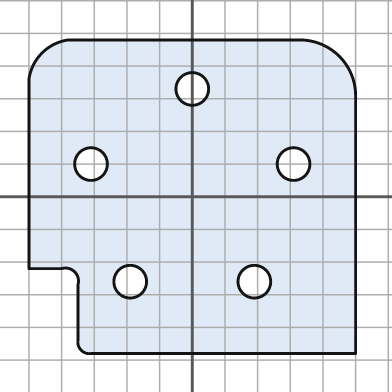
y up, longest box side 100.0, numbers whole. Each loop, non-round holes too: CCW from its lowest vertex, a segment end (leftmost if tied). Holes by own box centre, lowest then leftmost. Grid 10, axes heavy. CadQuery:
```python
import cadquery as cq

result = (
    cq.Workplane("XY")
    .moveTo(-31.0, -48.0)
    .lineTo(50.0, -48.0)
    .lineTo(50.0, 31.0)
    .threePointArc((45.0, 43.0), (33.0, 48.0))
    .lineTo(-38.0, 48.0)
    .threePointArc((-46.0, 44.0), (-50.0, 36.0))
    .lineTo(-50.0, -22.0)
    .lineTo(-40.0, -22.0)
    .threePointArc((-36.0, -23.0), (-35.0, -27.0))
    .lineTo(-35.0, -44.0)
    .threePointArc((-34.0, -47.0), (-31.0, -48.0))
    .close()
    .moveTo(-19.0, -26.0)
    .circle(5.0)
    .moveTo(19.0, -26.0)
    .circle(5.0)
    .moveTo(-31.0, 10.0)
    .circle(5.0)
    .moveTo(31.0, 10.0)
    .circle(5.0)
    .moveTo(0.0, 33.0)
    .circle(5.0)
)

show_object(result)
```